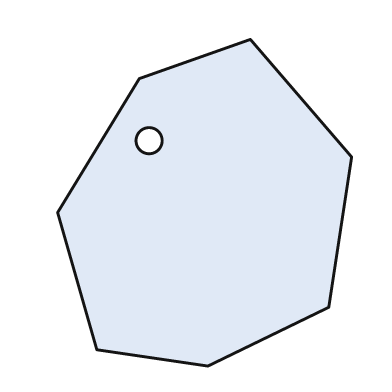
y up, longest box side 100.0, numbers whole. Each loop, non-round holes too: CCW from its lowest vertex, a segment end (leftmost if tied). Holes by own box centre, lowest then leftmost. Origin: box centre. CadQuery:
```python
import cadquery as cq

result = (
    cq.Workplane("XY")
    .moveTo(1.0, -50.0)
    .lineTo(38.0, -32.0)
    .lineTo(45.0, 14.0)
    .lineTo(14.0, 50.0)
    .lineTo(-20.0, 38.0)
    .lineTo(-45.0, -3.0)
    .lineTo(-33.0, -45.0)
    .close()
    .moveTo(-17.0, 19.0)
    .circle(4.0)
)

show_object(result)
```